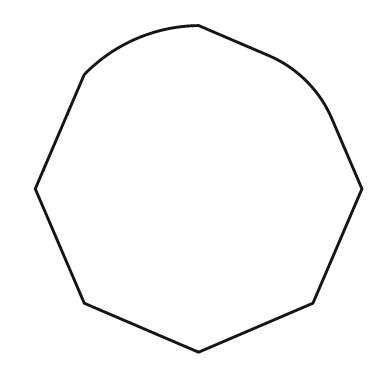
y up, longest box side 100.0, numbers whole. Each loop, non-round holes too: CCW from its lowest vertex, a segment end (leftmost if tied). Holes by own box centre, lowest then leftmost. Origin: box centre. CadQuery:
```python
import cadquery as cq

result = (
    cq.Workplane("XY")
    .moveTo(0.0, -50.0)
    .lineTo(35.0, -35.0)
    .lineTo(50.0, 0.0)
    .lineTo(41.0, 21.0)
    .threePointArc((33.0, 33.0), (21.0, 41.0))
    .lineTo(0.0, 50.0)
    .threePointArc((-19.0, 46.0), (-35.0, 35.0))
    .lineTo(-50.0, 0.0)
    .lineTo(-35.0, -35.0)
    .close()
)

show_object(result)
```